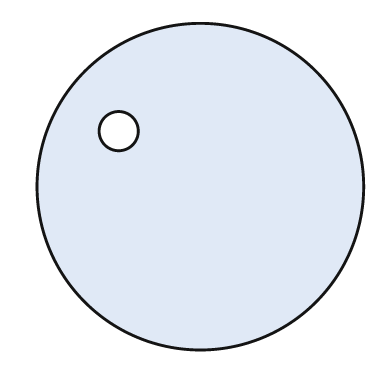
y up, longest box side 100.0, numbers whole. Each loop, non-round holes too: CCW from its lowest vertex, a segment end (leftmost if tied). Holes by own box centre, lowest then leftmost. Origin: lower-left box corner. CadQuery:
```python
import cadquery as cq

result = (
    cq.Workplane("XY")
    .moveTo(50.0, 50.0)
    .circle(50.0)
    .moveTo(25.0, 67.0)
    .circle(6.0)
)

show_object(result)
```